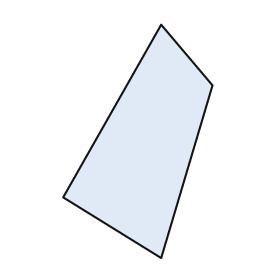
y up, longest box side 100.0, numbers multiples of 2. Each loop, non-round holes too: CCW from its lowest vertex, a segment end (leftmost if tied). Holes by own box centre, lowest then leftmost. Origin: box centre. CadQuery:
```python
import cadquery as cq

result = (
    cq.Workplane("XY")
    .moveTo(10.0, -50.0)
    .lineTo(32.0, 24.0)
    .lineTo(10.0, 50.0)
    .lineTo(-32.0, -24.0)
    .close()
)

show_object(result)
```